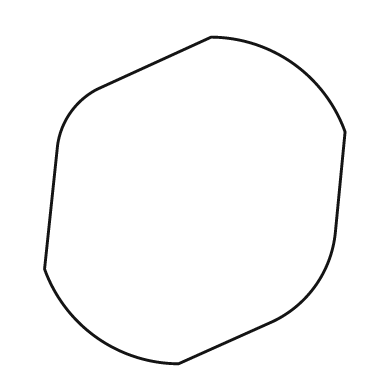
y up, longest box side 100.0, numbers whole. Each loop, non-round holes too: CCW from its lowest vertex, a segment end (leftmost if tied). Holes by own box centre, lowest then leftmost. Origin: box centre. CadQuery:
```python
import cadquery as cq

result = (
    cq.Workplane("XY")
    .moveTo(-5.0, -50.0)
    .lineTo(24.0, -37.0)
    .threePointArc((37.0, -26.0), (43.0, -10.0))
    .lineTo(46.0, 21.0)
    .threePointArc((30.0, 42.0), (5.0, 50.0))
    .lineTo(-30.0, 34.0)
    .threePointArc((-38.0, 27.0), (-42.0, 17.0))
    .lineTo(-46.0, -21.0)
    .threePointArc((-30.0, -42.0), (-5.0, -50.0))
    .close()
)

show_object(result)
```